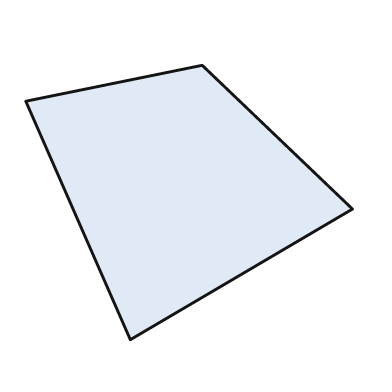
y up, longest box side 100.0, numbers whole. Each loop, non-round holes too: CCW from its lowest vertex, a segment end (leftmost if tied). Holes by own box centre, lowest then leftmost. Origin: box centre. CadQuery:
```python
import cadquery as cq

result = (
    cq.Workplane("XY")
    .moveTo(-18.0, -42.0)
    .lineTo(50.0, -2.0)
    .lineTo(4.0, 42.0)
    .lineTo(-50.0, 31.0)
    .close()
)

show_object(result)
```